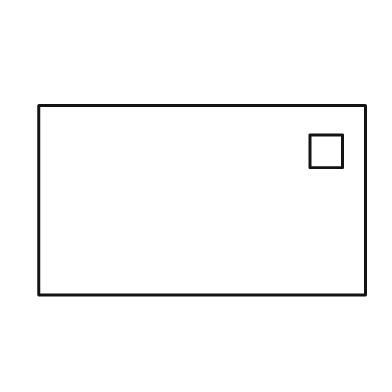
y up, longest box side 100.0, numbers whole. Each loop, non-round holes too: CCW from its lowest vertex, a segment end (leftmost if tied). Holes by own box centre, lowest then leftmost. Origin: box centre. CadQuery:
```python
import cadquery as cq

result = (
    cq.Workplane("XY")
    .moveTo(-50.0, -29.0)
    .lineTo(50.0, -29.0)
    .lineTo(50.0, 29.0)
    .lineTo(-50.0, 29.0)
    .close()
    .moveTo(33.0, 10.0)
    .lineTo(43.0, 10.0)
    .lineTo(43.0, 20.0)
    .lineTo(33.0, 20.0)
    .close()
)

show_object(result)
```